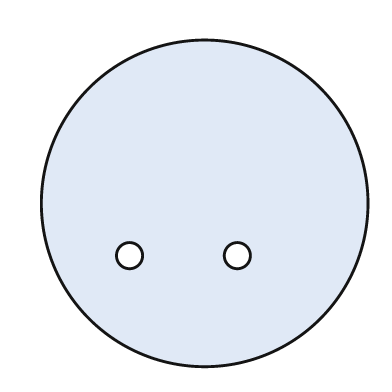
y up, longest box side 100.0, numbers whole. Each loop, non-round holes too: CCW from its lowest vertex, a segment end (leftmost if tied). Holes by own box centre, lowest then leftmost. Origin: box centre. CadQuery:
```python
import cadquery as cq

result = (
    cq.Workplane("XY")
    .moveTo(0.0, 0.0)
    .circle(50.0)
    .moveTo(-23.0, -16.0)
    .circle(4.0)
    .moveTo(10.0, -16.0)
    .circle(4.0)
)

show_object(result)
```